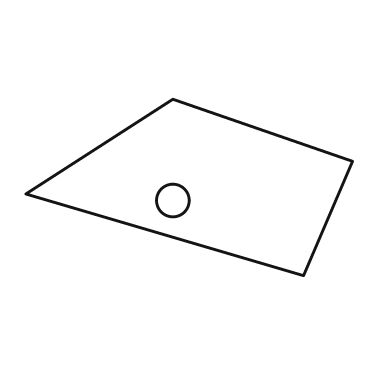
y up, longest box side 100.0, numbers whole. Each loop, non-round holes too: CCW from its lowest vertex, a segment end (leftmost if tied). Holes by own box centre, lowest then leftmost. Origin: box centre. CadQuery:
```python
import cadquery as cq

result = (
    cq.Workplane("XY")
    .moveTo(35.0, -27.0)
    .lineTo(50.0, 8.0)
    .lineTo(-5.0, 27.0)
    .lineTo(-50.0, -2.0)
    .close()
    .moveTo(-5.0, -4.0)
    .circle(5.0)
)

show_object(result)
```